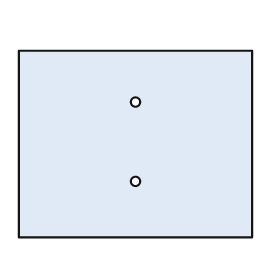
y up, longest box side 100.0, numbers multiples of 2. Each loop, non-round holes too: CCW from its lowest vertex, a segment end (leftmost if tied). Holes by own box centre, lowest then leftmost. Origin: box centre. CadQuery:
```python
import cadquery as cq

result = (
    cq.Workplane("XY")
    .moveTo(-50.0, -40.0)
    .lineTo(50.0, -40.0)
    .lineTo(50.0, 40.0)
    .lineTo(-50.0, 40.0)
    .close()
    .moveTo(0.0, -16.0)
    .circle(2.0)
    .moveTo(0.0, 18.0)
    .circle(2.0)
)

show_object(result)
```